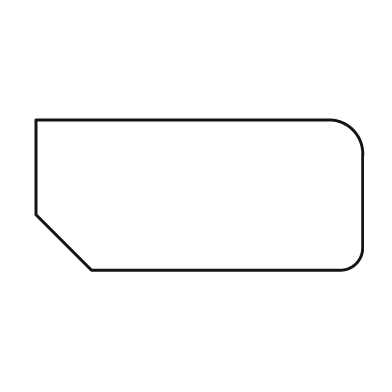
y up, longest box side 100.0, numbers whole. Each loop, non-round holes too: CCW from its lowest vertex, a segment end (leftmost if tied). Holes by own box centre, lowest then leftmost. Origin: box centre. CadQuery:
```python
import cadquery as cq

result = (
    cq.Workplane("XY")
    .moveTo(-33.0, -23.0)
    .lineTo(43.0, -23.0)
    .threePointArc((48.0, -21.0), (50.0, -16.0))
    .lineTo(50.0, 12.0)
    .threePointArc((47.0, 20.0), (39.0, 23.0))
    .lineTo(-50.0, 23.0)
    .lineTo(-50.0, -6.0)
    .close()
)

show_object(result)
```